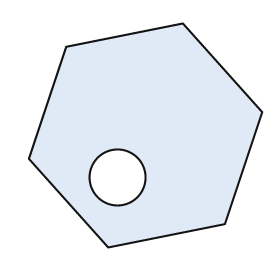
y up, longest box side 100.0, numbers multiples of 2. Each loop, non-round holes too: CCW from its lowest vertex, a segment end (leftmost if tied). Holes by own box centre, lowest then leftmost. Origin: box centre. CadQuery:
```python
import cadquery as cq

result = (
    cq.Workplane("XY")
    .moveTo(-16.0, -48.0)
    .lineTo(34.0, -38.0)
    .lineTo(50.0, 10.0)
    .lineTo(16.0, 48.0)
    .lineTo(-34.0, 38.0)
    .lineTo(-50.0, -10.0)
    .close()
    .moveTo(-12.0, -18.0)
    .circle(12.0)
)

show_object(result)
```